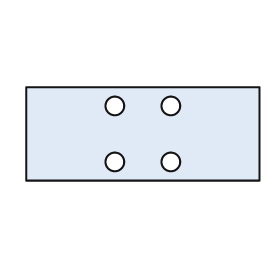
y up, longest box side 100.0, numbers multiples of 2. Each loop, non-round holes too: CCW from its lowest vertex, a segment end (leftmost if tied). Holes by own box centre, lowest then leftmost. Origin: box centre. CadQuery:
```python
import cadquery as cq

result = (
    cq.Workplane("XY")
    .moveTo(-50.0, -20.0)
    .lineTo(50.0, -20.0)
    .lineTo(50.0, 20.0)
    .lineTo(-50.0, 20.0)
    .close()
    .moveTo(-12.0, -12.0)
    .circle(4.0)
    .moveTo(12.0, -12.0)
    .circle(4.0)
    .moveTo(-12.0, 12.0)
    .circle(4.0)
    .moveTo(12.0, 12.0)
    .circle(4.0)
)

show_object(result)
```